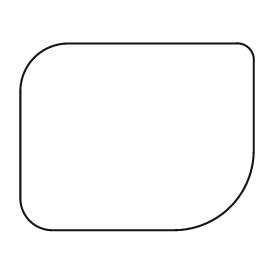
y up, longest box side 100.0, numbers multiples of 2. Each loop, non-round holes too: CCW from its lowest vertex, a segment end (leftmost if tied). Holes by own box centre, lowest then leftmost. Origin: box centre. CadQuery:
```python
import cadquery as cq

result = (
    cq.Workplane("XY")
    .moveTo(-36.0, -40.0)
    .lineTo(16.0, -40.0)
    .threePointArc((40.0, -30.0), (50.0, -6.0))
    .lineTo(50.0, 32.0)
    .threePointArc((48.0, 38.0), (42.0, 40.0))
    .lineTo(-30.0, 40.0)
    .threePointArc((-44.0, 34.0), (-50.0, 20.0))
    .lineTo(-50.0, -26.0)
    .threePointArc((-46.0, -36.0), (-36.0, -40.0))
    .close()
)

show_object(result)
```